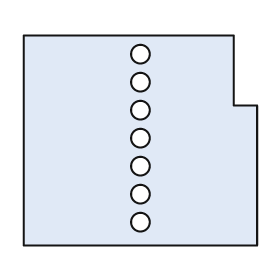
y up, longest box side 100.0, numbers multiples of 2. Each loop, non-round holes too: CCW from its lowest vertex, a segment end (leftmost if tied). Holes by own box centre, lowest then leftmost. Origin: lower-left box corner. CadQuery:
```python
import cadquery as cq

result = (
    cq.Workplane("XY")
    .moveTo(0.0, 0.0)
    .lineTo(100.0, 0.0)
    .lineTo(100.0, 60.0)
    .lineTo(90.0, 60.0)
    .lineTo(90.0, 90.0)
    .lineTo(0.0, 90.0)
    .close()
    .moveTo(50.0, 10.0)
    .circle(4.0)
    .moveTo(50.0, 22.0)
    .circle(4.0)
    .moveTo(50.0, 34.0)
    .circle(4.0)
    .moveTo(50.0, 46.0)
    .circle(4.0)
    .moveTo(50.0, 58.0)
    .circle(4.0)
    .moveTo(50.0, 70.0)
    .circle(4.0)
    .moveTo(50.0, 82.0)
    .circle(4.0)
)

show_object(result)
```